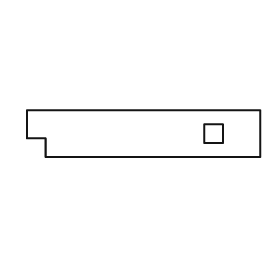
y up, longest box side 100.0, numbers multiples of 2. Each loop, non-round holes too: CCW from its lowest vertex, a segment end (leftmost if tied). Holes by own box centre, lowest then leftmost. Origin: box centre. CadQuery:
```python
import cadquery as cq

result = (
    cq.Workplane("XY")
    .moveTo(-42.0, -10.0)
    .lineTo(50.0, -10.0)
    .lineTo(50.0, 10.0)
    .lineTo(-50.0, 10.0)
    .lineTo(-50.0, -2.0)
    .lineTo(-42.0, -2.0)
    .close()
    .moveTo(26.0, -4.0)
    .lineTo(34.0, -4.0)
    .lineTo(34.0, 4.0)
    .lineTo(26.0, 4.0)
    .close()
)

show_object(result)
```